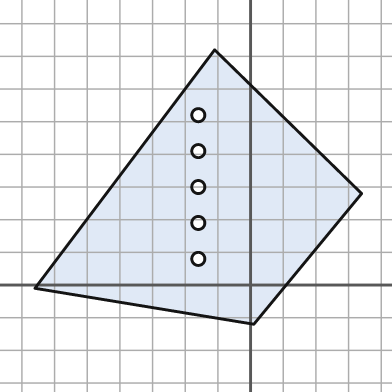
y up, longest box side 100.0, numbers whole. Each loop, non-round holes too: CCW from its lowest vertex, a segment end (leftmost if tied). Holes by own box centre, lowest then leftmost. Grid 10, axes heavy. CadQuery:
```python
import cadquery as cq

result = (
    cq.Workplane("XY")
    .moveTo(1.0, -12.0)
    .lineTo(34.0, 28.0)
    .lineTo(-11.0, 72.0)
    .lineTo(-66.0, -1.0)
    .close()
    .moveTo(-16.0, 8.0)
    .circle(2.0)
    .moveTo(-16.0, 19.0)
    .circle(2.0)
    .moveTo(-16.0, 30.0)
    .circle(2.0)
    .moveTo(-16.0, 41.0)
    .circle(2.0)
    .moveTo(-16.0, 52.0)
    .circle(2.0)
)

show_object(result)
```